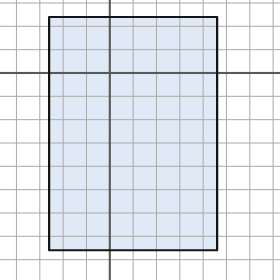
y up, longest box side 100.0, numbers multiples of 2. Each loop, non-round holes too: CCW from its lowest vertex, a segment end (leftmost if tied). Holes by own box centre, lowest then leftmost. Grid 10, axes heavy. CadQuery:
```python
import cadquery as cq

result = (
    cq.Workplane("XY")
    .moveTo(-26.0, -76.0)
    .lineTo(46.0, -76.0)
    .lineTo(46.0, 24.0)
    .lineTo(-26.0, 24.0)
    .close()
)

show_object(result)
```